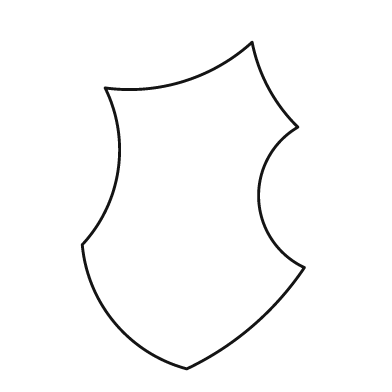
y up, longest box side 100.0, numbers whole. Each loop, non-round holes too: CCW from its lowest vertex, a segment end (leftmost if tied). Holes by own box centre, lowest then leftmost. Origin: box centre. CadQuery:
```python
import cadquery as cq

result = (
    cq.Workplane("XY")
    .moveTo(-2.0, -50.0)
    .threePointArc((18.0, -37.0), (34.0, -19.0))
    .threePointArc((20.0, 2.0), (32.0, 24.0))
    .threePointArc((23.0, 36.0), (18.0, 50.0))
    .threePointArc((-3.0, 38.0), (-27.0, 36.0))
    .threePointArc((-23.0, 11.0), (-34.0, -12.0))
    .threePointArc((-24.0, -36.0), (-2.0, -50.0))
    .close()
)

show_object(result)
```